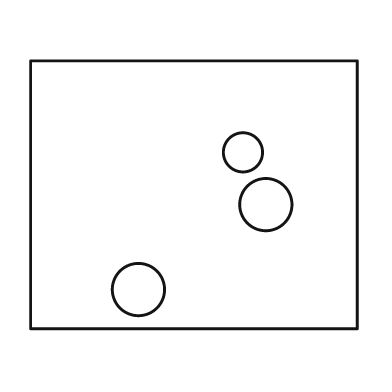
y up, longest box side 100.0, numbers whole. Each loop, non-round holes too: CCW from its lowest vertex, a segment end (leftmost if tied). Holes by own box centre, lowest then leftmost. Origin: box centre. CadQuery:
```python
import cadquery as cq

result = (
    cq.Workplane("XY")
    .moveTo(-50.0, -41.0)
    .lineTo(50.0, -41.0)
    .lineTo(50.0, 41.0)
    .lineTo(-50.0, 41.0)
    .close()
    .moveTo(-17.0, -29.0)
    .circle(8.0)
    .moveTo(22.0, -3.0)
    .circle(8.0)
    .moveTo(15.0, 13.0)
    .circle(6.0)
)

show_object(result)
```